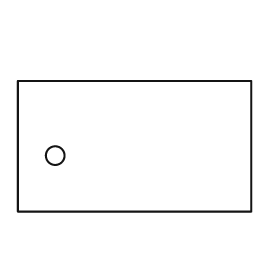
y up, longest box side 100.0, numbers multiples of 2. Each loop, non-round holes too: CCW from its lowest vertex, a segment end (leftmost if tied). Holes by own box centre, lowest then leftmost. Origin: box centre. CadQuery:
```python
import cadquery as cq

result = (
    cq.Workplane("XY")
    .moveTo(-50.0, -28.0)
    .lineTo(50.0, -28.0)
    .lineTo(50.0, 28.0)
    .lineTo(-50.0, 28.0)
    .close()
    .moveTo(-34.0, -4.0)
    .circle(4.0)
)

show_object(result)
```